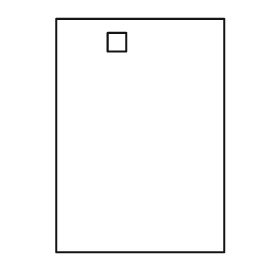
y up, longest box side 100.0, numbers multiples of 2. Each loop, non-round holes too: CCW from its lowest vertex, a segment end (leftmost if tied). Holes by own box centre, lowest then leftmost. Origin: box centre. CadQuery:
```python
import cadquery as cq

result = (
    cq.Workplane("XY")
    .moveTo(-36.0, -50.0)
    .lineTo(36.0, -50.0)
    .lineTo(36.0, 50.0)
    .lineTo(-36.0, 50.0)
    .close()
    .moveTo(-14.0, 36.0)
    .lineTo(-6.0, 36.0)
    .lineTo(-6.0, 44.0)
    .lineTo(-14.0, 44.0)
    .close()
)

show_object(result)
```